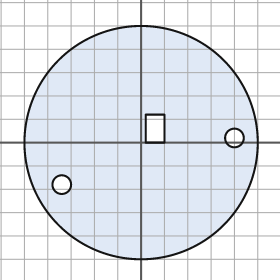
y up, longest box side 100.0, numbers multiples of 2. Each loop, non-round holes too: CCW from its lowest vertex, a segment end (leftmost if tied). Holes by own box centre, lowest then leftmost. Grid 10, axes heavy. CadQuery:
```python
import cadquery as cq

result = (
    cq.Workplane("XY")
    .moveTo(0.0, 0.0)
    .circle(50.0)
    .moveTo(-34.0, -18.0)
    .circle(4.0)
    .moveTo(40.0, 2.0)
    .circle(4.0)
    .moveTo(2.0, 0.0)
    .lineTo(10.0, 0.0)
    .lineTo(10.0, 12.0)
    .lineTo(2.0, 12.0)
    .close()
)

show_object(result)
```